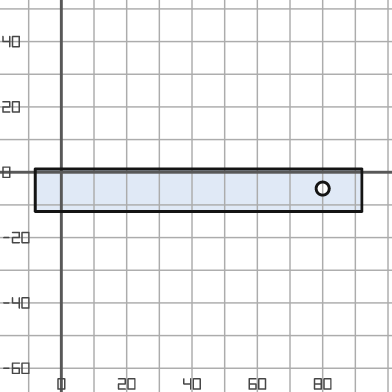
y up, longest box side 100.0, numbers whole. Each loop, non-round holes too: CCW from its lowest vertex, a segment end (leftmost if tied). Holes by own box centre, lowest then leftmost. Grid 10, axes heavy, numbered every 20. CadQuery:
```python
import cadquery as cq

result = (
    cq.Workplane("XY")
    .moveTo(-8.0, -12.0)
    .lineTo(92.0, -12.0)
    .lineTo(92.0, 1.0)
    .lineTo(-8.0, 1.0)
    .close()
    .moveTo(80.0, -5.0)
    .circle(2.0)
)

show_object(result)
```